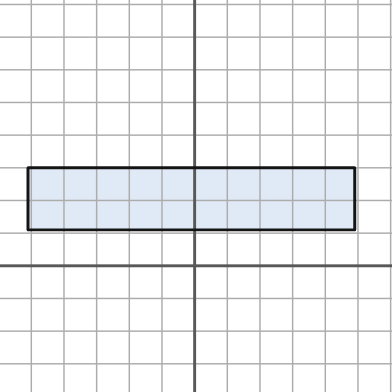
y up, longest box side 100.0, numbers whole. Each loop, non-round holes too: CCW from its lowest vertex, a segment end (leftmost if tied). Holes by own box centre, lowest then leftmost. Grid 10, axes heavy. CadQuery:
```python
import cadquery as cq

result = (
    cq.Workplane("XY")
    .moveTo(-51.0, 11.0)
    .lineTo(49.0, 11.0)
    .lineTo(49.0, 30.0)
    .lineTo(-51.0, 30.0)
    .close()
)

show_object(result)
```